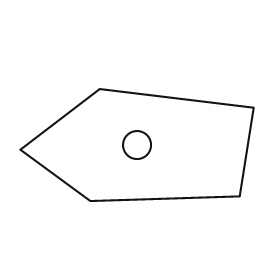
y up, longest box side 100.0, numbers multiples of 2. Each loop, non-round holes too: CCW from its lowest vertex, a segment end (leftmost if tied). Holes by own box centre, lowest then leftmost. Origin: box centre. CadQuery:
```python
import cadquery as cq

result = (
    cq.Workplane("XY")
    .moveTo(-20.0, -24.0)
    .lineTo(44.0, -22.0)
    .lineTo(50.0, 16.0)
    .lineTo(-16.0, 24.0)
    .lineTo(-50.0, -2.0)
    .close()
    .moveTo(0.0, 0.0)
    .circle(6.0)
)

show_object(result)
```